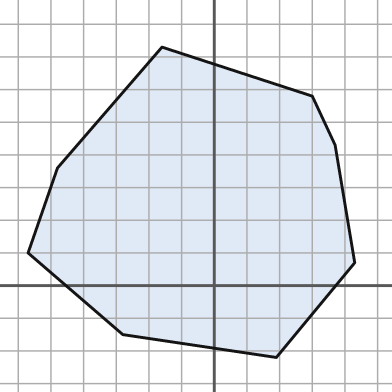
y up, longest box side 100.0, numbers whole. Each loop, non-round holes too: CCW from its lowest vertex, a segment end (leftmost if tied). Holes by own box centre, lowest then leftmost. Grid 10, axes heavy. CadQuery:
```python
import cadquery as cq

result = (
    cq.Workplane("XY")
    .moveTo(19.0, -22.0)
    .lineTo(43.0, 7.0)
    .lineTo(37.0, 43.0)
    .lineTo(30.0, 58.0)
    .lineTo(-16.0, 73.0)
    .lineTo(-48.0, 36.0)
    .lineTo(-57.0, 10.0)
    .lineTo(-28.0, -15.0)
    .close()
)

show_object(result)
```